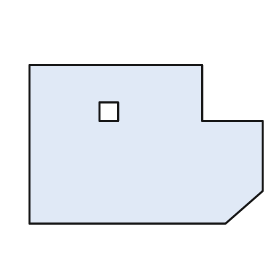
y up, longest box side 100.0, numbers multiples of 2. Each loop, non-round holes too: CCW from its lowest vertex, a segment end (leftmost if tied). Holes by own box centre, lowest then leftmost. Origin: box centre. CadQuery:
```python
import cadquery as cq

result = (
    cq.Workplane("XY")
    .moveTo(-50.0, -34.0)
    .lineTo(34.0, -34.0)
    .lineTo(50.0, -20.0)
    .lineTo(50.0, 10.0)
    .lineTo(24.0, 10.0)
    .lineTo(24.0, 34.0)
    .lineTo(-50.0, 34.0)
    .close()
    .moveTo(-20.0, 10.0)
    .lineTo(-12.0, 10.0)
    .lineTo(-12.0, 18.0)
    .lineTo(-20.0, 18.0)
    .close()
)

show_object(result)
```